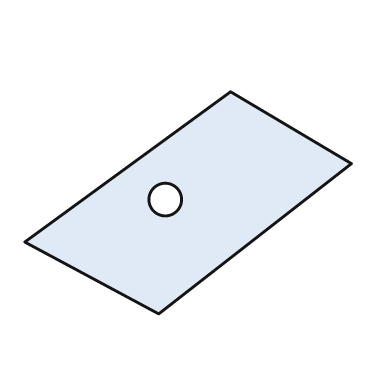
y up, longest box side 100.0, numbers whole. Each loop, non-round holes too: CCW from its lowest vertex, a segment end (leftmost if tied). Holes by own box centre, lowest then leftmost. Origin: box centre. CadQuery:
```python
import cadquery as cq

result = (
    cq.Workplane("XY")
    .moveTo(-9.0, -34.0)
    .lineTo(50.0, 12.0)
    .lineTo(13.0, 34.0)
    .lineTo(-50.0, -12.0)
    .close()
    .moveTo(-7.0, 1.0)
    .circle(5.0)
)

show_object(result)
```